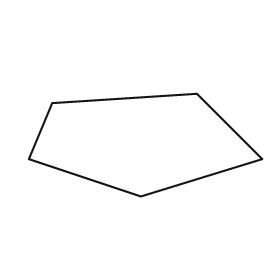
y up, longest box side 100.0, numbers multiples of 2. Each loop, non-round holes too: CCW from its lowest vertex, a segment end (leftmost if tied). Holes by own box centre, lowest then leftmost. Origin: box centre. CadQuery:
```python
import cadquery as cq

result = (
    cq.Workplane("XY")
    .moveTo(-2.0, -22.0)
    .lineTo(50.0, -6.0)
    .lineTo(22.0, 22.0)
    .lineTo(-40.0, 18.0)
    .lineTo(-50.0, -6.0)
    .close()
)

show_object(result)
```